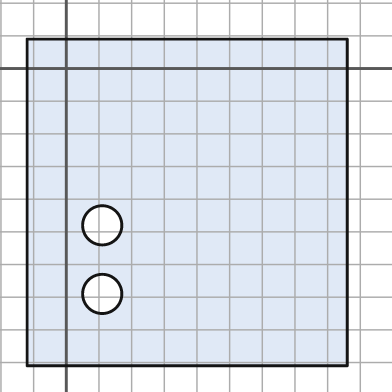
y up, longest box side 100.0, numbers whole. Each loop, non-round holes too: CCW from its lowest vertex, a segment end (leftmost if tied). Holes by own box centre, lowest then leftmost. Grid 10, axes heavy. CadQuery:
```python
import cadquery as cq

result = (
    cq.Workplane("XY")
    .moveTo(-12.0, -91.0)
    .lineTo(86.0, -91.0)
    .lineTo(86.0, 9.0)
    .lineTo(-12.0, 9.0)
    .close()
    .moveTo(11.0, -69.0)
    .circle(6.0)
    .moveTo(11.0, -48.0)
    .circle(6.0)
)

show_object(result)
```